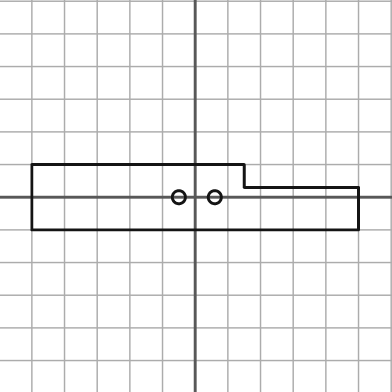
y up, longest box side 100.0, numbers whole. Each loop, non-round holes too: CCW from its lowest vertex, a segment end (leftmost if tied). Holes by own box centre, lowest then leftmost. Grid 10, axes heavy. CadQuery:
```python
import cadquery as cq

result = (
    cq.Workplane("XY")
    .moveTo(-50.0, -10.0)
    .lineTo(50.0, -10.0)
    .lineTo(50.0, 3.0)
    .lineTo(15.0, 3.0)
    .lineTo(15.0, 10.0)
    .lineTo(-50.0, 10.0)
    .close()
    .moveTo(-5.0, 0.0)
    .circle(2.0)
    .moveTo(6.0, 0.0)
    .circle(2.0)
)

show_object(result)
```